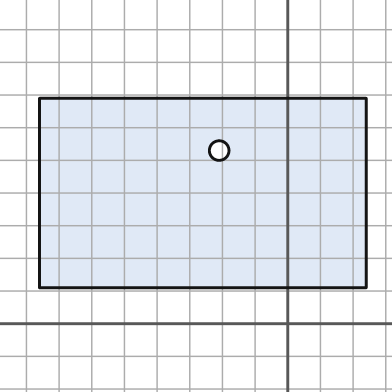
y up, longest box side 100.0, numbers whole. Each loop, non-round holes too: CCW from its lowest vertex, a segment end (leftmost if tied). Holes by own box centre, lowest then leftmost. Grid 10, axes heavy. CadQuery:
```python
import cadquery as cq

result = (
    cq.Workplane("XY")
    .moveTo(-76.0, 11.0)
    .lineTo(24.0, 11.0)
    .lineTo(24.0, 69.0)
    .lineTo(-76.0, 69.0)
    .close()
    .moveTo(-21.0, 53.0)
    .circle(3.0)
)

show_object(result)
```